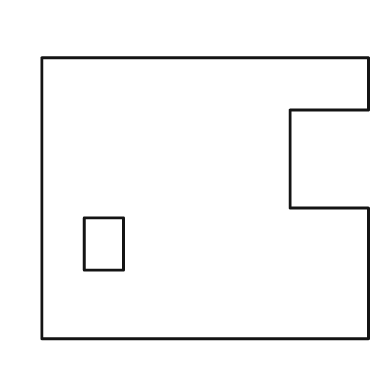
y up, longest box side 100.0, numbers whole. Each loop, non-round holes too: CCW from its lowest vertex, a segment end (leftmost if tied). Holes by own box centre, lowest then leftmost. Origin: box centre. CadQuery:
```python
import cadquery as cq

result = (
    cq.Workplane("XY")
    .moveTo(-50.0, -43.0)
    .lineTo(50.0, -43.0)
    .lineTo(50.0, -3.0)
    .lineTo(26.0, -3.0)
    .lineTo(26.0, 27.0)
    .lineTo(50.0, 27.0)
    .lineTo(50.0, 43.0)
    .lineTo(-50.0, 43.0)
    .close()
    .moveTo(-37.0, -22.0)
    .lineTo(-25.0, -22.0)
    .lineTo(-25.0, -6.0)
    .lineTo(-37.0, -6.0)
    .close()
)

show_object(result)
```